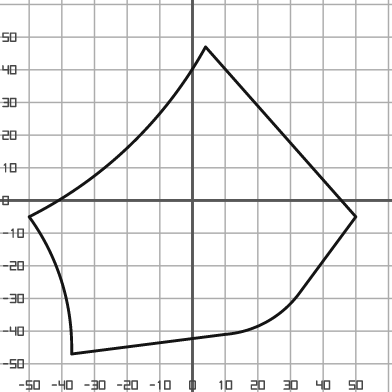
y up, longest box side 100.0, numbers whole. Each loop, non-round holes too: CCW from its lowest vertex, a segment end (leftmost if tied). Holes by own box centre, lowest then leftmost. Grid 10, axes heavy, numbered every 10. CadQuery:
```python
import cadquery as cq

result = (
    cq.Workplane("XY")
    .moveTo(-37.0, -47.0)
    .lineTo(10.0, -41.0)
    .threePointArc((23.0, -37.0), (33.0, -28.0))
    .lineTo(50.0, -5.0)
    .lineTo(4.0, 47.0)
    .threePointArc((-19.0, 17.0), (-50.0, -5.0))
    .threePointArc((-40.0, -25.0), (-37.0, -47.0))
    .close()
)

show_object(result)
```